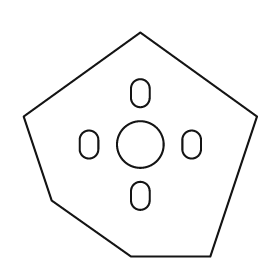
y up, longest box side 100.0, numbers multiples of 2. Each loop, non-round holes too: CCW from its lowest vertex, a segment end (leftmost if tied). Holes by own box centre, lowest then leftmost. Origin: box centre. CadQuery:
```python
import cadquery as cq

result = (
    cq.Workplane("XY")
    .moveTo(-4.0, -48.0)
    .lineTo(30.0, -48.0)
    .lineTo(50.0, 12.0)
    .lineTo(0.0, 48.0)
    .lineTo(-50.0, 12.0)
    .lineTo(-38.0, -24.0)
    .close()
    .moveTo(-4.0, -24.0)
    .threePointArc((0.0, -28.0), (4.0, -24.0))
    .lineTo(4.0, -20.0)
    .threePointArc((0.0, -16.0), (-4.0, -20.0))
    .close()
    .moveTo(-26.0, -2.0)
    .threePointArc((-22.0, -6.0), (-18.0, -2.0))
    .lineTo(-18.0, 2.0)
    .threePointArc((-22.0, 6.0), (-26.0, 2.0))
    .close()
    .moveTo(0.0, 0.0)
    .circle(10.0)
    .moveTo(18.0, -2.0)
    .threePointArc((22.0, -6.0), (26.0, -2.0))
    .lineTo(26.0, 2.0)
    .threePointArc((22.0, 6.0), (18.0, 2.0))
    .close()
    .moveTo(-4.0, 20.0)
    .threePointArc((0.0, 16.0), (4.0, 20.0))
    .lineTo(4.0, 24.0)
    .threePointArc((0.0, 28.0), (-4.0, 24.0))
    .close()
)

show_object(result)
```